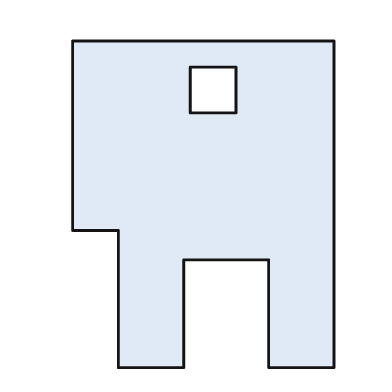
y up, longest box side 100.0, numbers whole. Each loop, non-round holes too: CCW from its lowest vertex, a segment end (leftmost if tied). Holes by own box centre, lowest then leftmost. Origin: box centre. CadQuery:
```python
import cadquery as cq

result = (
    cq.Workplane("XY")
    .moveTo(-26.0, -50.0)
    .lineTo(-6.0, -50.0)
    .lineTo(-6.0, -17.0)
    .lineTo(20.0, -17.0)
    .lineTo(20.0, -50.0)
    .lineTo(40.0, -50.0)
    .lineTo(40.0, 50.0)
    .lineTo(-40.0, 50.0)
    .lineTo(-40.0, -8.0)
    .lineTo(-26.0, -8.0)
    .close()
    .moveTo(-4.0, 28.0)
    .lineTo(10.0, 28.0)
    .lineTo(10.0, 42.0)
    .lineTo(-4.0, 42.0)
    .close()
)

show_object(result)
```